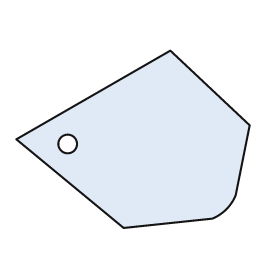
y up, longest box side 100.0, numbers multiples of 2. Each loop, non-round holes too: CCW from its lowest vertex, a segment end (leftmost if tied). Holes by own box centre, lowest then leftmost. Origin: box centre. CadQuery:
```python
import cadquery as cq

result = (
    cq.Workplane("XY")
    .moveTo(-4.0, -38.0)
    .lineTo(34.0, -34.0)
    .threePointArc((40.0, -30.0), (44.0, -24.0))
    .lineTo(50.0, 6.0)
    .lineTo(16.0, 38.0)
    .lineTo(-50.0, 0.0)
    .close()
    .moveTo(-28.0, -2.0)
    .circle(4.0)
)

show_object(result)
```